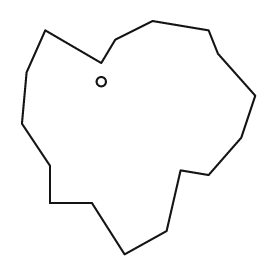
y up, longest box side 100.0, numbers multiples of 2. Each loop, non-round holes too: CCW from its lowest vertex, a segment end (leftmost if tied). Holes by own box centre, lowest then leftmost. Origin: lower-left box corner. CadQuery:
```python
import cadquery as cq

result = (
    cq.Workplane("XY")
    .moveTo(44.0, 0.0)
    .lineTo(62.0, 10.0)
    .lineTo(68.0, 36.0)
    .lineTo(80.0, 34.0)
    .lineTo(94.0, 50.0)
    .lineTo(100.0, 68.0)
    .lineTo(84.0, 86.0)
    .lineTo(80.0, 96.0)
    .lineTo(56.0, 100.0)
    .lineTo(40.0, 92.0)
    .lineTo(34.0, 82.0)
    .lineTo(10.0, 96.0)
    .lineTo(2.0, 78.0)
    .lineTo(0.0, 56.0)
    .lineTo(12.0, 38.0)
    .lineTo(12.0, 22.0)
    .lineTo(30.0, 22.0)
    .close()
    .moveTo(34.0, 74.0)
    .circle(2.0)
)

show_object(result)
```